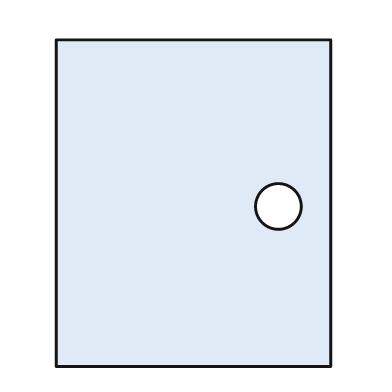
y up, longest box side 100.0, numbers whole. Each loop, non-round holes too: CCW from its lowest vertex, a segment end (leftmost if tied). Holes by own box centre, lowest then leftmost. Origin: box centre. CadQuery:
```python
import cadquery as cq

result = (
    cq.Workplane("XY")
    .moveTo(-42.0, -50.0)
    .lineTo(42.0, -50.0)
    .lineTo(42.0, 50.0)
    .lineTo(-42.0, 50.0)
    .close()
    .moveTo(26.0, -1.0)
    .circle(7.0)
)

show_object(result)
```